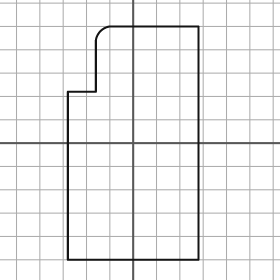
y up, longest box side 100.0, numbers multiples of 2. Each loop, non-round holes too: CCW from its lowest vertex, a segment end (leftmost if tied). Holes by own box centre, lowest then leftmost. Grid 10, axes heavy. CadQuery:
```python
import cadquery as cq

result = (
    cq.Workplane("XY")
    .moveTo(-28.0, -50.0)
    .lineTo(28.0, -50.0)
    .lineTo(28.0, 50.0)
    .lineTo(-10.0, 50.0)
    .threePointArc((-14.0, 48.0), (-16.0, 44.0))
    .lineTo(-16.0, 22.0)
    .lineTo(-28.0, 22.0)
    .close()
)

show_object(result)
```